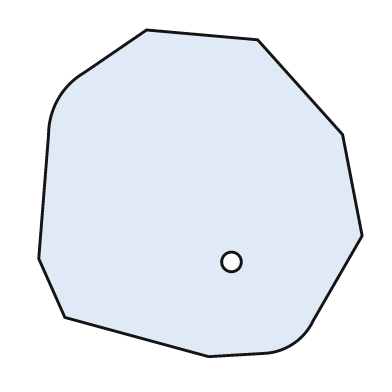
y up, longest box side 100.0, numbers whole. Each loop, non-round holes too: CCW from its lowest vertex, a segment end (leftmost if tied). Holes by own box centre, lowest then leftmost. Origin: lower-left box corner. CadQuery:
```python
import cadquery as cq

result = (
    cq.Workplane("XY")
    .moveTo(52.0, 0.0)
    .lineTo(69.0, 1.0)
    .threePointArc((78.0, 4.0), (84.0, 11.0))
    .lineTo(99.0, 37.0)
    .lineTo(93.0, 68.0)
    .lineTo(67.0, 97.0)
    .lineTo(33.0, 100.0)
    .lineTo(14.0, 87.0)
    .threePointArc((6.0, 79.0), (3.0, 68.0))
    .lineTo(0.0, 30.0)
    .lineTo(8.0, 12.0)
    .close()
    .moveTo(59.0, 29.0)
    .circle(3.0)
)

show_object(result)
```